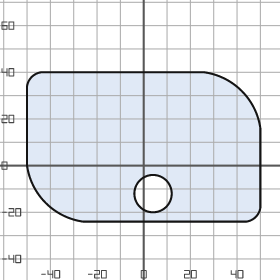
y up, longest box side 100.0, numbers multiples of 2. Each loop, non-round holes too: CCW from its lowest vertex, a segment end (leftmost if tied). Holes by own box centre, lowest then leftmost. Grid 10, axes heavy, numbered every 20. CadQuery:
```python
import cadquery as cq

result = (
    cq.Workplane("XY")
    .moveTo(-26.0, -24.0)
    .lineTo(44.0, -24.0)
    .threePointArc((48.0, -22.0), (50.0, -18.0))
    .lineTo(50.0, 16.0)
    .threePointArc((42.0, 32.0), (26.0, 40.0))
    .lineTo(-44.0, 40.0)
    .threePointArc((-48.0, 38.0), (-50.0, 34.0))
    .lineTo(-50.0, 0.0)
    .threePointArc((-42.0, -16.0), (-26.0, -24.0))
    .close()
    .moveTo(4.0, -12.0)
    .circle(8.0)
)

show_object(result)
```